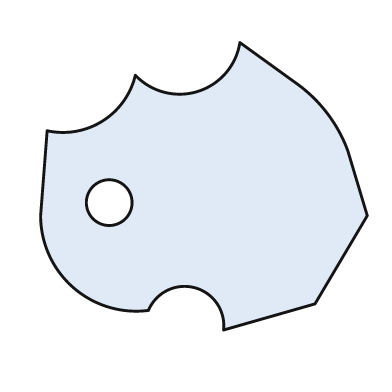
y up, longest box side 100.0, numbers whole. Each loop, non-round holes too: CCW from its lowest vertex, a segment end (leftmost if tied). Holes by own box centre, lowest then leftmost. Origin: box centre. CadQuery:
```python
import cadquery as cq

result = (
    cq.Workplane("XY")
    .moveTo(6.0, -44.0)
    .lineTo(34.0, -36.0)
    .lineTo(50.0, -9.0)
    .lineTo(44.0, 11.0)
    .threePointArc((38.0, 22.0), (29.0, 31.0))
    .lineTo(11.0, 44.0)
    .threePointArc((-2.0, 29.0), (-21.0, 34.0))
    .threePointArc((-31.0, 20.0), (-48.0, 17.0))
    .lineTo(-50.0, -9.0)
    .threePointArc((-40.0, -31.0), (-17.0, -38.0))
    .threePointArc((-3.0, -31.0), (6.0, -44.0))
    .close()
    .moveTo(-29.0, -5.0)
    .circle(7.0)
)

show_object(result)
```